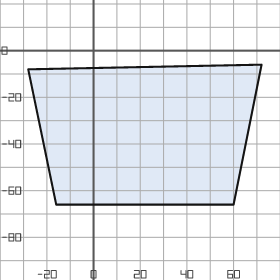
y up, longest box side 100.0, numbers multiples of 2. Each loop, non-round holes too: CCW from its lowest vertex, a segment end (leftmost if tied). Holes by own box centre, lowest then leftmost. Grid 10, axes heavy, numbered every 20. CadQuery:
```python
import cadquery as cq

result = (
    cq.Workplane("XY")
    .moveTo(-16.0, -66.0)
    .lineTo(60.0, -66.0)
    .lineTo(72.0, -6.0)
    .lineTo(-28.0, -8.0)
    .close()
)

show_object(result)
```